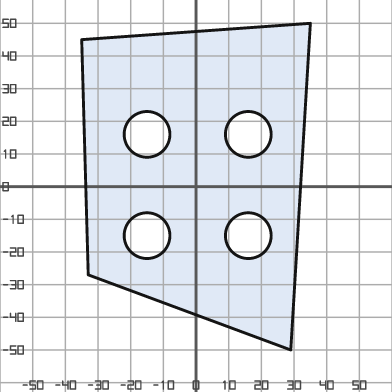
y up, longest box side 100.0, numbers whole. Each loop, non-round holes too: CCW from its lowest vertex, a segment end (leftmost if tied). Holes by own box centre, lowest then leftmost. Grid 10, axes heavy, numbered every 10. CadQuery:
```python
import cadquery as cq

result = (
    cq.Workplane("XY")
    .moveTo(29.0, -50.0)
    .lineTo(35.0, 50.0)
    .lineTo(-35.0, 45.0)
    .lineTo(-33.0, -27.0)
    .close()
    .moveTo(-15.0, -15.0)
    .circle(7.0)
    .moveTo(16.0, -15.0)
    .circle(7.0)
    .moveTo(-15.0, 16.0)
    .circle(7.0)
    .moveTo(16.0, 16.0)
    .circle(7.0)
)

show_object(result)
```